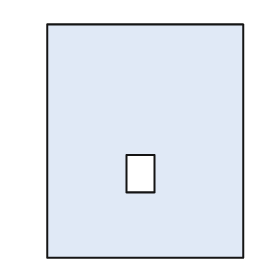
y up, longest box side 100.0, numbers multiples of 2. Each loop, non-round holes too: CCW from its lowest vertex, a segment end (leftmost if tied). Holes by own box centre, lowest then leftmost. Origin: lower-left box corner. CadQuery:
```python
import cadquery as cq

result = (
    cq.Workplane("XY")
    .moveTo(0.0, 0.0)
    .lineTo(84.0, 0.0)
    .lineTo(84.0, 100.0)
    .lineTo(0.0, 100.0)
    .close()
    .moveTo(34.0, 28.0)
    .lineTo(46.0, 28.0)
    .lineTo(46.0, 44.0)
    .lineTo(34.0, 44.0)
    .close()
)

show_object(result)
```